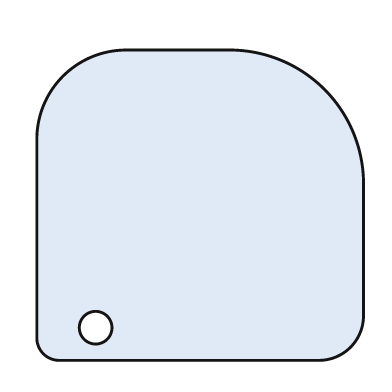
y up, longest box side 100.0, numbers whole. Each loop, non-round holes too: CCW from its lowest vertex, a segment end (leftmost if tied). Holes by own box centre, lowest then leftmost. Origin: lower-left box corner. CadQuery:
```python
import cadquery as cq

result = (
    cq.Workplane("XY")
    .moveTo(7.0, 0.0)
    .lineTo(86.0, 0.0)
    .threePointArc((96.0, 4.0), (100.0, 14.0))
    .lineTo(100.0, 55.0)
    .threePointArc((88.0, 83.0), (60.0, 95.0))
    .lineTo(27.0, 95.0)
    .threePointArc((8.0, 87.0), (0.0, 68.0))
    .lineTo(0.0, 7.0)
    .threePointArc((2.0, 2.0), (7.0, 0.0))
    .close()
    .moveTo(18.0, 10.0)
    .circle(5.0)
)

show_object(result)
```